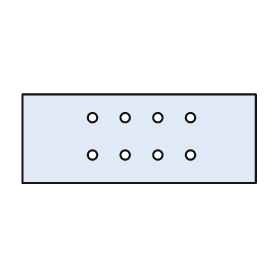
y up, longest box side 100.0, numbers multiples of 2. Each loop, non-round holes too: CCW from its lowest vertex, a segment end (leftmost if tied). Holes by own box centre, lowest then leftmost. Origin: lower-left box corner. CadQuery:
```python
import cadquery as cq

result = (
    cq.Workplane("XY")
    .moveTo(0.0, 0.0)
    .lineTo(100.0, 0.0)
    .lineTo(100.0, 38.0)
    .lineTo(0.0, 38.0)
    .close()
    .moveTo(30.0, 12.0)
    .circle(2.0)
    .moveTo(44.0, 12.0)
    .circle(2.0)
    .moveTo(58.0, 12.0)
    .circle(2.0)
    .moveTo(72.0, 12.0)
    .circle(2.0)
    .moveTo(30.0, 28.0)
    .circle(2.0)
    .moveTo(44.0, 28.0)
    .circle(2.0)
    .moveTo(58.0, 28.0)
    .circle(2.0)
    .moveTo(72.0, 28.0)
    .circle(2.0)
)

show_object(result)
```